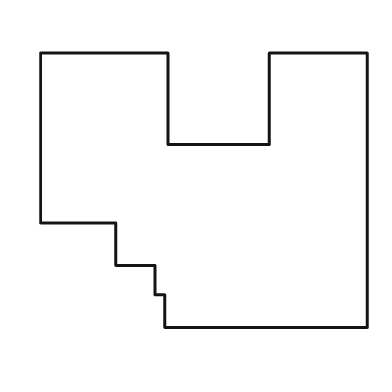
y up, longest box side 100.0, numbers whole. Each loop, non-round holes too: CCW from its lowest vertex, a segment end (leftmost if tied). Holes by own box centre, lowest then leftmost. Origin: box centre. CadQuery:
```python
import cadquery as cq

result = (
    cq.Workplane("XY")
    .moveTo(-12.0, -42.0)
    .lineTo(50.0, -42.0)
    .lineTo(50.0, 42.0)
    .lineTo(20.0, 42.0)
    .lineTo(20.0, 14.0)
    .lineTo(-11.0, 14.0)
    .lineTo(-11.0, 42.0)
    .lineTo(-50.0, 42.0)
    .lineTo(-50.0, -10.0)
    .lineTo(-27.0, -10.0)
    .lineTo(-27.0, -23.0)
    .lineTo(-15.0, -23.0)
    .lineTo(-15.0, -32.0)
    .lineTo(-12.0, -32.0)
    .close()
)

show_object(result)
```